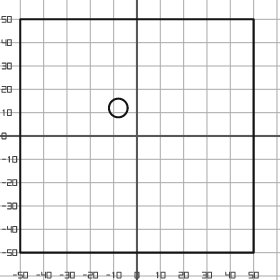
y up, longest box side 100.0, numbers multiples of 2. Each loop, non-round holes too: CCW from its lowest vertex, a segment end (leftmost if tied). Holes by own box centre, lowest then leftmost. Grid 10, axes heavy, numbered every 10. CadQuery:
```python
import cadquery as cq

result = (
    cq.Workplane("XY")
    .moveTo(-50.0, -50.0)
    .lineTo(50.0, -50.0)
    .lineTo(50.0, 50.0)
    .lineTo(-50.0, 50.0)
    .close()
    .moveTo(-8.0, 12.0)
    .circle(4.0)
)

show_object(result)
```